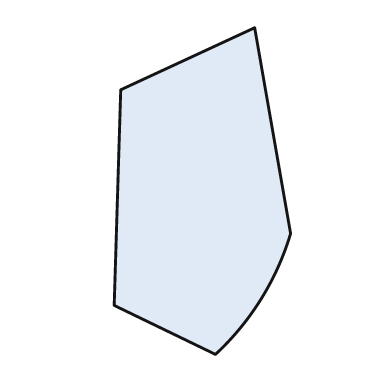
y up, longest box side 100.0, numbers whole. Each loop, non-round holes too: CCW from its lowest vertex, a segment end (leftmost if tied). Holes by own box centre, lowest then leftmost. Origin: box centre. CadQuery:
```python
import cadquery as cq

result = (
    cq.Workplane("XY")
    .moveTo(4.0, -50.0)
    .threePointArc((18.0, -33.0), (27.0, -13.0))
    .lineTo(16.0, 50.0)
    .lineTo(-25.0, 31.0)
    .lineTo(-27.0, -35.0)
    .close()
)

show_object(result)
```